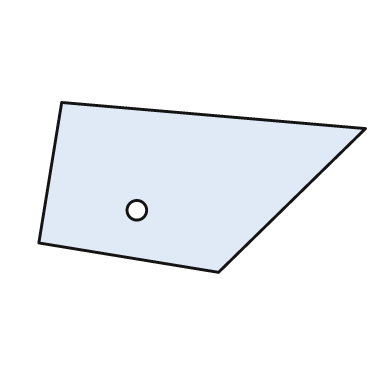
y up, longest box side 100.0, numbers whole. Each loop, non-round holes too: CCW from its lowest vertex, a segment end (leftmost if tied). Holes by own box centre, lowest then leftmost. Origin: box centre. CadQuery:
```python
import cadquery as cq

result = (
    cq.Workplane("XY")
    .moveTo(5.0, -26.0)
    .lineTo(50.0, 18.0)
    .lineTo(-43.0, 26.0)
    .lineTo(-50.0, -17.0)
    .close()
    .moveTo(-20.0, -7.0)
    .circle(3.0)
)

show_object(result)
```